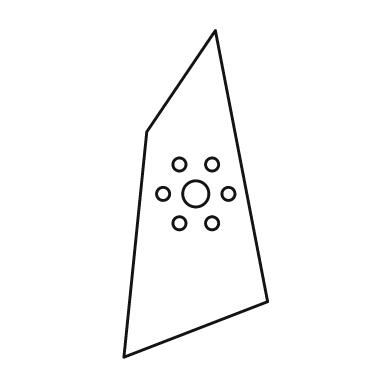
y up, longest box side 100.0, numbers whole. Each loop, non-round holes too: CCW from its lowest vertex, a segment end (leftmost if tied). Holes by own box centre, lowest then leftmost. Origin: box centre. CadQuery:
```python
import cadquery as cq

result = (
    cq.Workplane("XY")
    .moveTo(-22.0, -50.0)
    .lineTo(22.0, -33.0)
    .lineTo(6.0, 50.0)
    .lineTo(-15.0, 19.0)
    .close()
    .moveTo(-5.0, -9.0)
    .circle(2.0)
    .moveTo(5.0, -9.0)
    .circle(2.0)
    .moveTo(-10.0, 0.0)
    .circle(2.0)
    .moveTo(0.0, 0.0)
    .circle(4.0)
    .moveTo(10.0, 0.0)
    .circle(2.0)
    .moveTo(-5.0, 9.0)
    .circle(2.0)
    .moveTo(5.0, 9.0)
    .circle(2.0)
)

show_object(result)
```